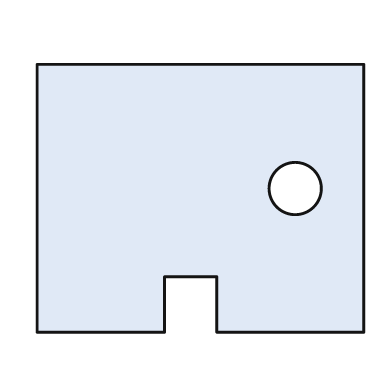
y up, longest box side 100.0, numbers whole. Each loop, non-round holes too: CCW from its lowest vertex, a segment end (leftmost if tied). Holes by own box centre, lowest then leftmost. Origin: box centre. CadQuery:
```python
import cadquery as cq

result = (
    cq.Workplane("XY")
    .moveTo(-50.0, -41.0)
    .lineTo(-11.0, -41.0)
    .lineTo(-11.0, -24.0)
    .lineTo(5.0, -24.0)
    .lineTo(5.0, -41.0)
    .lineTo(50.0, -41.0)
    .lineTo(50.0, 41.0)
    .lineTo(-50.0, 41.0)
    .close()
    .moveTo(29.0, 3.0)
    .circle(8.0)
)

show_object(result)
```